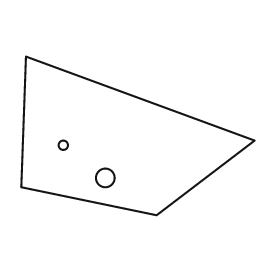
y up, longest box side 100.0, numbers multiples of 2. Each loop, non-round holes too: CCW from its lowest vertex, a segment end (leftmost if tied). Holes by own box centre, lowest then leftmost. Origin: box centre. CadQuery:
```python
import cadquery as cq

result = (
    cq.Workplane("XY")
    .moveTo(8.0, -34.0)
    .lineTo(50.0, -2.0)
    .lineTo(-48.0, 34.0)
    .lineTo(-50.0, -22.0)
    .close()
    .moveTo(-14.0, -18.0)
    .circle(4.0)
    .moveTo(-32.0, -4.0)
    .circle(2.0)
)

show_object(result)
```